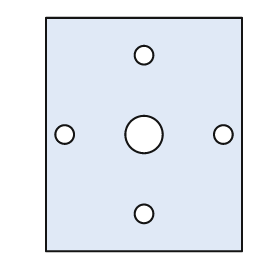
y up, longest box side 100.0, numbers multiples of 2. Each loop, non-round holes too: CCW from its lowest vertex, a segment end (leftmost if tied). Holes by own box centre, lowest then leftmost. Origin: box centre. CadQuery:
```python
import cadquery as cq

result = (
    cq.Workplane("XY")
    .moveTo(-42.0, -50.0)
    .lineTo(42.0, -50.0)
    .lineTo(42.0, 50.0)
    .lineTo(-42.0, 50.0)
    .close()
    .moveTo(0.0, -34.0)
    .circle(4.0)
    .moveTo(-34.0, 0.0)
    .circle(4.0)
    .moveTo(0.0, 0.0)
    .circle(8.0)
    .moveTo(34.0, 0.0)
    .circle(4.0)
    .moveTo(0.0, 34.0)
    .circle(4.0)
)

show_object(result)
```